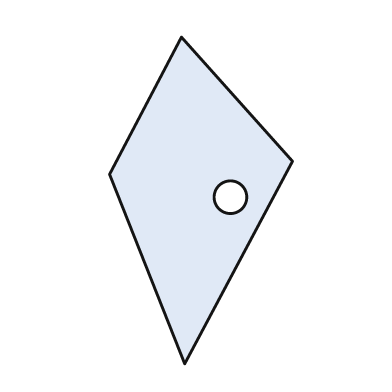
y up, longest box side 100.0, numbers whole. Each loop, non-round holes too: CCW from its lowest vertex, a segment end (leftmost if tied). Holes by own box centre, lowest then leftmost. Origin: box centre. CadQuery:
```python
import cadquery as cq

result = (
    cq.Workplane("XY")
    .moveTo(-5.0, -50.0)
    .lineTo(28.0, 12.0)
    .lineTo(-6.0, 50.0)
    .lineTo(-28.0, 8.0)
    .close()
    .moveTo(9.0, 1.0)
    .circle(5.0)
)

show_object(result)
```